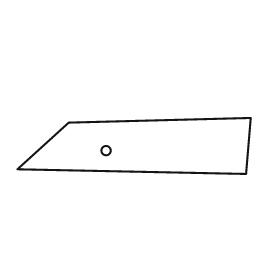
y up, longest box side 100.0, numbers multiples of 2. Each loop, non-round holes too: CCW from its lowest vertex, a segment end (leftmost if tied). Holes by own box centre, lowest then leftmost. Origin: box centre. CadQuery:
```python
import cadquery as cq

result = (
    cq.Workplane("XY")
    .moveTo(48.0, -12.0)
    .lineTo(50.0, 12.0)
    .lineTo(-28.0, 10.0)
    .lineTo(-50.0, -10.0)
    .close()
    .moveTo(-12.0, -2.0)
    .circle(2.0)
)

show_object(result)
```